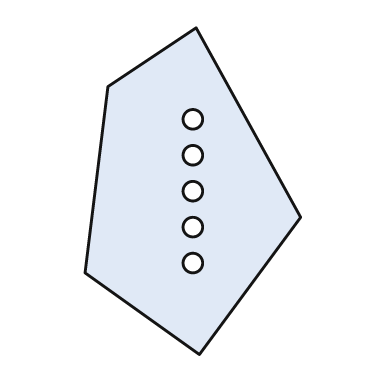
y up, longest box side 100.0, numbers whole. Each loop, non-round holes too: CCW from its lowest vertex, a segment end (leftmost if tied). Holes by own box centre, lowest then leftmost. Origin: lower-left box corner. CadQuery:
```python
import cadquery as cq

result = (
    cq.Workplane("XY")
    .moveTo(35.0, 0.0)
    .lineTo(66.0, 42.0)
    .lineTo(34.0, 100.0)
    .lineTo(7.0, 82.0)
    .lineTo(0.0, 25.0)
    .close()
    .moveTo(33.0, 28.0)
    .circle(3.0)
    .moveTo(33.0, 39.0)
    .circle(3.0)
    .moveTo(33.0, 50.0)
    .circle(3.0)
    .moveTo(33.0, 61.0)
    .circle(3.0)
    .moveTo(33.0, 72.0)
    .circle(3.0)
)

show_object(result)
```